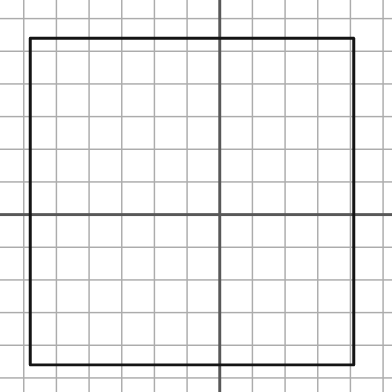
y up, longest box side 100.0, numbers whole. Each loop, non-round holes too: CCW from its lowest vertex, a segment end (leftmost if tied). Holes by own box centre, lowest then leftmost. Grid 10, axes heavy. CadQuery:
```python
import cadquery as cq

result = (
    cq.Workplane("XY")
    .moveTo(-58.0, -46.0)
    .lineTo(41.0, -46.0)
    .lineTo(41.0, 54.0)
    .lineTo(-58.0, 54.0)
    .close()
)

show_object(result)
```